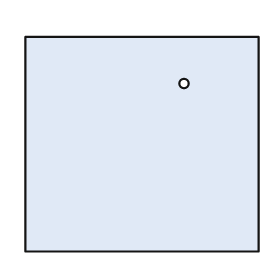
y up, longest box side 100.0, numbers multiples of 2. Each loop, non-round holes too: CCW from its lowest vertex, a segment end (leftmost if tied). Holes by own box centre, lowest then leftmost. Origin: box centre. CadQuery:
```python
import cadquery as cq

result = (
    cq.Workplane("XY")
    .moveTo(-50.0, -46.0)
    .lineTo(50.0, -46.0)
    .lineTo(50.0, 46.0)
    .lineTo(-50.0, 46.0)
    .close()
    .moveTo(18.0, 26.0)
    .circle(2.0)
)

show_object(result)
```